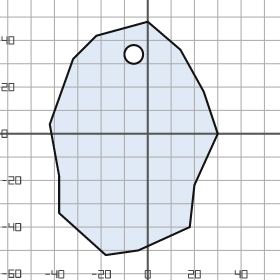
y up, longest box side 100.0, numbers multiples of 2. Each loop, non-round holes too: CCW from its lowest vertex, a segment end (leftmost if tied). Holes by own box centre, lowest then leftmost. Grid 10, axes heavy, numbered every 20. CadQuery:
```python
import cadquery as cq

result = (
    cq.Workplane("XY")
    .moveTo(-18.0, -52.0)
    .lineTo(-4.0, -50.0)
    .lineTo(18.0, -40.0)
    .lineTo(20.0, -22.0)
    .lineTo(30.0, 0.0)
    .lineTo(24.0, 18.0)
    .lineTo(14.0, 36.0)
    .lineTo(0.0, 48.0)
    .lineTo(-22.0, 42.0)
    .lineTo(-32.0, 32.0)
    .lineTo(-42.0, 4.0)
    .lineTo(-38.0, -18.0)
    .lineTo(-38.0, -34.0)
    .close()
    .moveTo(-6.0, 34.0)
    .circle(4.0)
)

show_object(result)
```